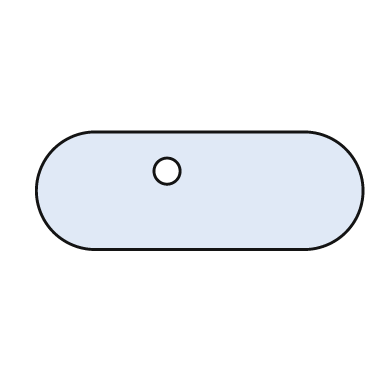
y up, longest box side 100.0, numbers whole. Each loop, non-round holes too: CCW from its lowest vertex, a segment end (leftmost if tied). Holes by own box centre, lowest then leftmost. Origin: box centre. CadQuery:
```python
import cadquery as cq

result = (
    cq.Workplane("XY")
    .moveTo(-32.0, -18.0)
    .lineTo(32.0, -18.0)
    .threePointArc((50.0, 0.0), (32.0, 18.0))
    .lineTo(-32.0, 18.0)
    .threePointArc((-50.0, 0.0), (-32.0, -18.0))
    .close()
    .moveTo(-10.0, 6.0)
    .circle(4.0)
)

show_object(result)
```